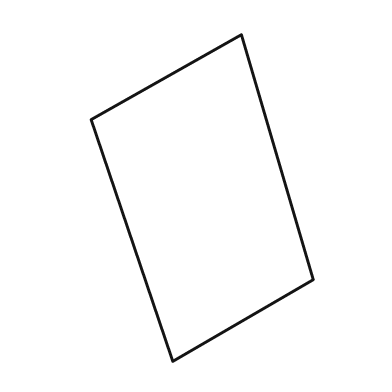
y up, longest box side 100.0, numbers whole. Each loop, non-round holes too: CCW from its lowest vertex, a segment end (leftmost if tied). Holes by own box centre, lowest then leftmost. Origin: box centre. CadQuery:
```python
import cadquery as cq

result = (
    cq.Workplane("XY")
    .moveTo(-9.0, -50.0)
    .lineTo(34.0, -25.0)
    .lineTo(12.0, 50.0)
    .lineTo(-34.0, 24.0)
    .close()
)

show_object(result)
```